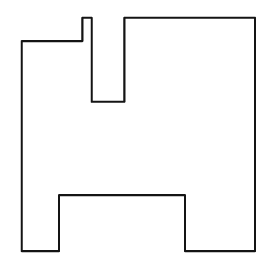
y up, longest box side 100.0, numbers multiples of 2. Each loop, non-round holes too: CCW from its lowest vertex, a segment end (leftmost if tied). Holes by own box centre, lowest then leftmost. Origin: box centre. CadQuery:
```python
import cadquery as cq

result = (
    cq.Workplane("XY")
    .moveTo(-50.0, -50.0)
    .lineTo(-34.0, -50.0)
    .lineTo(-34.0, -26.0)
    .lineTo(20.0, -26.0)
    .lineTo(20.0, -50.0)
    .lineTo(50.0, -50.0)
    .lineTo(50.0, 50.0)
    .lineTo(-6.0, 50.0)
    .lineTo(-6.0, 14.0)
    .lineTo(-20.0, 14.0)
    .lineTo(-20.0, 50.0)
    .lineTo(-24.0, 50.0)
    .lineTo(-24.0, 40.0)
    .lineTo(-50.0, 40.0)
    .close()
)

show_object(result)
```